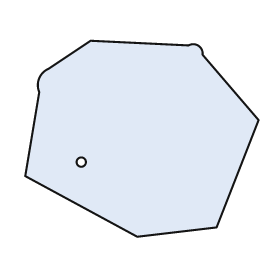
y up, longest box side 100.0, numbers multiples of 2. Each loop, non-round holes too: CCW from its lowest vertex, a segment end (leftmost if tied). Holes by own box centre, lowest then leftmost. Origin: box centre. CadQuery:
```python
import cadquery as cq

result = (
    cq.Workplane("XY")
    .moveTo(-2.0, -42.0)
    .lineTo(32.0, -38.0)
    .lineTo(50.0, 8.0)
    .lineTo(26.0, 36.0)
    .threePointArc((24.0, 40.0), (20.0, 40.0))
    .lineTo(-22.0, 42.0)
    .lineTo(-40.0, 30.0)
    .threePointArc((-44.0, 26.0), (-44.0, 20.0))
    .lineTo(-50.0, -16.0)
    .close()
    .moveTo(-26.0, -10.0)
    .circle(2.0)
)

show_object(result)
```